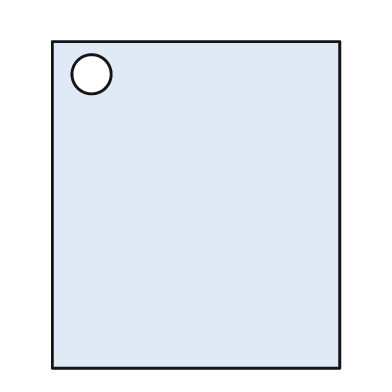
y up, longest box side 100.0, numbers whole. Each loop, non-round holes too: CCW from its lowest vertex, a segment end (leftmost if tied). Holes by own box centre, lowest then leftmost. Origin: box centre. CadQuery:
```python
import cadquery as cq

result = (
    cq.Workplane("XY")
    .moveTo(-44.0, -50.0)
    .lineTo(44.0, -50.0)
    .lineTo(44.0, 50.0)
    .lineTo(-44.0, 50.0)
    .close()
    .moveTo(-32.0, 40.0)
    .circle(6.0)
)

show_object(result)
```